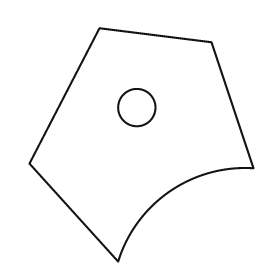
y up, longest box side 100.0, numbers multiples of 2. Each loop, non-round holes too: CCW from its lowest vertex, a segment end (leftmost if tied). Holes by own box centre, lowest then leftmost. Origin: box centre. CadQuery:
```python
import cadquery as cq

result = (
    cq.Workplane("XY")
    .moveTo(-10.0, -50.0)
    .threePointArc((12.0, -20.0), (48.0, -10.0))
    .lineTo(30.0, 44.0)
    .lineTo(-18.0, 50.0)
    .lineTo(-48.0, -8.0)
    .close()
    .moveTo(-2.0, 16.0)
    .circle(8.0)
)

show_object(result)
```